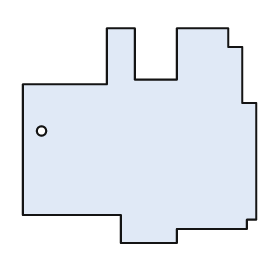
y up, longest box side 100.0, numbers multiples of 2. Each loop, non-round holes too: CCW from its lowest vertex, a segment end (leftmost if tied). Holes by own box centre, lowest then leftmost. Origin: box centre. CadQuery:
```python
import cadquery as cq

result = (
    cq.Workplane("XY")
    .moveTo(-8.0, -46.0)
    .lineTo(16.0, -46.0)
    .lineTo(16.0, -40.0)
    .lineTo(46.0, -40.0)
    .lineTo(46.0, -36.0)
    .lineTo(50.0, -36.0)
    .lineTo(50.0, 14.0)
    .lineTo(44.0, 14.0)
    .lineTo(44.0, 38.0)
    .lineTo(38.0, 38.0)
    .lineTo(38.0, 46.0)
    .lineTo(16.0, 46.0)
    .lineTo(16.0, 24.0)
    .lineTo(-2.0, 24.0)
    .lineTo(-2.0, 46.0)
    .lineTo(-14.0, 46.0)
    .lineTo(-14.0, 22.0)
    .lineTo(-50.0, 22.0)
    .lineTo(-50.0, -34.0)
    .lineTo(-8.0, -34.0)
    .close()
    .moveTo(-42.0, 2.0)
    .circle(2.0)
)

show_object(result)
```